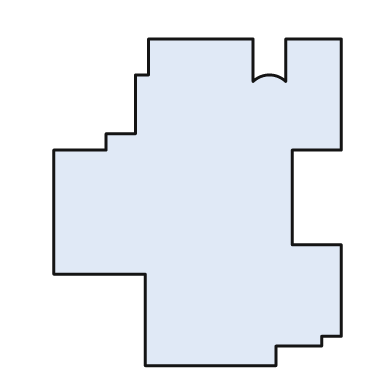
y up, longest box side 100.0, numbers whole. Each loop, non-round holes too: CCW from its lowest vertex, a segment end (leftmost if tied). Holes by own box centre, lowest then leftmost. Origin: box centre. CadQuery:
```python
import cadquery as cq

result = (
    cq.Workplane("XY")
    .moveTo(-16.0, -50.0)
    .lineTo(24.0, -50.0)
    .lineTo(24.0, -44.0)
    .lineTo(38.0, -44.0)
    .lineTo(38.0, -41.0)
    .lineTo(44.0, -41.0)
    .lineTo(44.0, -13.0)
    .lineTo(29.0, -13.0)
    .lineTo(29.0, 16.0)
    .lineTo(44.0, 16.0)
    .lineTo(44.0, 50.0)
    .lineTo(27.0, 50.0)
    .lineTo(27.0, 37.0)
    .threePointArc((22.0, 39.0), (17.0, 37.0))
    .lineTo(17.0, 50.0)
    .lineTo(-15.0, 50.0)
    .lineTo(-15.0, 39.0)
    .lineTo(-19.0, 39.0)
    .lineTo(-19.0, 21.0)
    .lineTo(-28.0, 21.0)
    .lineTo(-28.0, 16.0)
    .lineTo(-44.0, 16.0)
    .lineTo(-44.0, -22.0)
    .lineTo(-16.0, -22.0)
    .close()
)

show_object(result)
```